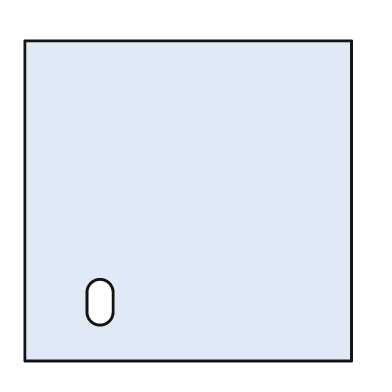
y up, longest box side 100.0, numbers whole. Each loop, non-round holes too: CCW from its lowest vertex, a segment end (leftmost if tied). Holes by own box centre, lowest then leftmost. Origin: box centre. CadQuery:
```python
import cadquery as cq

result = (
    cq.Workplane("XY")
    .moveTo(-50.0, -49.0)
    .lineTo(50.0, -49.0)
    .lineTo(50.0, 49.0)
    .lineTo(-50.0, 49.0)
    .close()
    .moveTo(-31.0, -34.0)
    .threePointArc((-27.0, -38.0), (-23.0, -34.0))
    .lineTo(-23.0, -28.0)
    .threePointArc((-27.0, -24.0), (-31.0, -28.0))
    .close()
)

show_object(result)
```